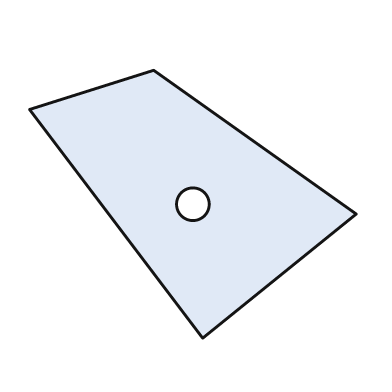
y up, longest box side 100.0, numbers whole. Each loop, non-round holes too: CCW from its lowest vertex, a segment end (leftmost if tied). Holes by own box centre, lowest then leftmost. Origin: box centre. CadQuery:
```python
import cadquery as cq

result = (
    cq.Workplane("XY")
    .moveTo(3.0, -41.0)
    .lineTo(50.0, -3.0)
    .lineTo(-12.0, 41.0)
    .lineTo(-50.0, 29.0)
    .close()
    .moveTo(0.0, 0.0)
    .circle(5.0)
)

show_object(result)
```